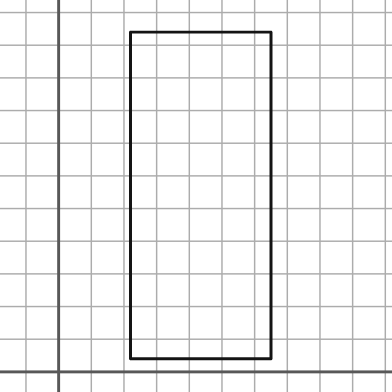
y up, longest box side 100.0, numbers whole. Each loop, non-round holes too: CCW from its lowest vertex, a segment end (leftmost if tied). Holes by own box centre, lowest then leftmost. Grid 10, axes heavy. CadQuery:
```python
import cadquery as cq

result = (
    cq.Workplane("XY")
    .moveTo(22.0, 4.0)
    .lineTo(65.0, 4.0)
    .lineTo(65.0, 104.0)
    .lineTo(22.0, 104.0)
    .close()
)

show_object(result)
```